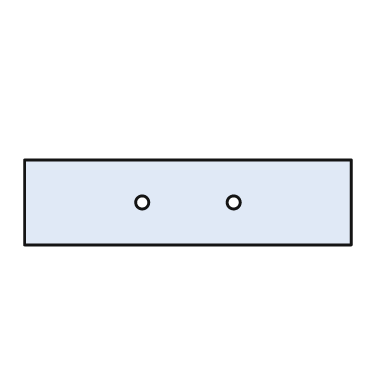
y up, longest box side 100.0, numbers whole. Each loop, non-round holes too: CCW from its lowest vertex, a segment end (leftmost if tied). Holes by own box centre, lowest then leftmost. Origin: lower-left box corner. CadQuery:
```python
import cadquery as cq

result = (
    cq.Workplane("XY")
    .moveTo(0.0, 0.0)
    .lineTo(100.0, 0.0)
    .lineTo(100.0, 26.0)
    .lineTo(0.0, 26.0)
    .close()
    .moveTo(36.0, 13.0)
    .circle(2.0)
    .moveTo(64.0, 13.0)
    .circle(2.0)
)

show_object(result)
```